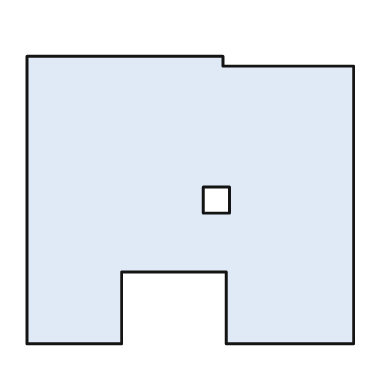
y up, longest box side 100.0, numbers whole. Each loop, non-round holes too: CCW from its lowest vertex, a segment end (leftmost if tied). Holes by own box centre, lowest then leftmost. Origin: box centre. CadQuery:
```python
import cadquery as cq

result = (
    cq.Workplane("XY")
    .moveTo(-50.0, -44.0)
    .lineTo(-21.0, -44.0)
    .lineTo(-21.0, -22.0)
    .lineTo(11.0, -22.0)
    .lineTo(11.0, -44.0)
    .lineTo(50.0, -44.0)
    .lineTo(50.0, 41.0)
    .lineTo(10.0, 41.0)
    .lineTo(10.0, 44.0)
    .lineTo(-50.0, 44.0)
    .close()
    .moveTo(4.0, -4.0)
    .lineTo(12.0, -4.0)
    .lineTo(12.0, 4.0)
    .lineTo(4.0, 4.0)
    .close()
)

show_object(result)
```